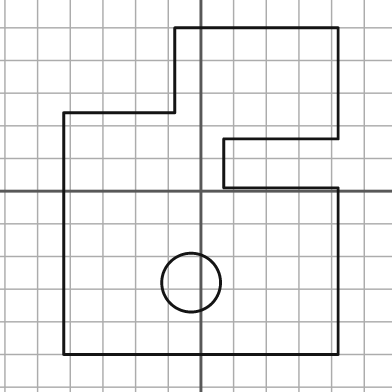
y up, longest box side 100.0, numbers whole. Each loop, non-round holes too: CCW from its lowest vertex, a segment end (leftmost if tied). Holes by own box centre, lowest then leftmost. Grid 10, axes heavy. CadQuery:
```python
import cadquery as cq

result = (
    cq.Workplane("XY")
    .moveTo(-42.0, -50.0)
    .lineTo(42.0, -50.0)
    .lineTo(42.0, 1.0)
    .lineTo(7.0, 1.0)
    .lineTo(7.0, 16.0)
    .lineTo(42.0, 16.0)
    .lineTo(42.0, 50.0)
    .lineTo(-8.0, 50.0)
    .lineTo(-8.0, 24.0)
    .lineTo(-42.0, 24.0)
    .close()
    .moveTo(-3.0, -28.0)
    .circle(9.0)
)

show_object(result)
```